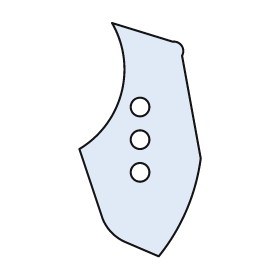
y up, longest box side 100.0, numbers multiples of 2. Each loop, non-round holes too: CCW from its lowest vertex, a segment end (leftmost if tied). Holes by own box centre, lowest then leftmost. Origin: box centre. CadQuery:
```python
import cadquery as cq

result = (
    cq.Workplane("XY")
    .moveTo(8.0, -50.0)
    .threePointArc((20.0, -30.0), (26.0, -8.0))
    .lineTo(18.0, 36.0)
    .threePointArc((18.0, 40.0), (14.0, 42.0))
    .lineTo(-12.0, 50.0)
    .threePointArc((-8.0, 20.0), (-26.0, -4.0))
    .lineTo(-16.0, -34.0)
    .threePointArc((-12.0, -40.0), (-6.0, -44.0))
    .close()
    .moveTo(0.0, -14.0)
    .circle(4.0)
    .moveTo(0.0, 0.0)
    .circle(4.0)
    .moveTo(0.0, 14.0)
    .circle(4.0)
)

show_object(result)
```